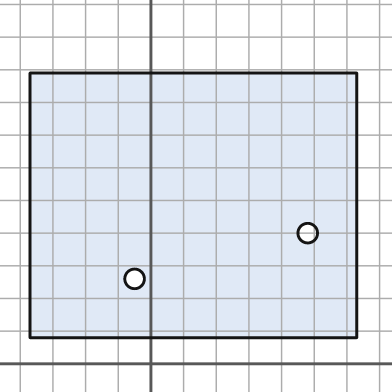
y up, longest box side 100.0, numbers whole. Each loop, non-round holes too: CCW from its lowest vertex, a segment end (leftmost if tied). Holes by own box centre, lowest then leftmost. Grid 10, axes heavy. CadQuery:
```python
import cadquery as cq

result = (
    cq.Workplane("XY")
    .moveTo(-37.0, 8.0)
    .lineTo(63.0, 8.0)
    .lineTo(63.0, 89.0)
    .lineTo(-37.0, 89.0)
    .close()
    .moveTo(-5.0, 26.0)
    .circle(3.0)
    .moveTo(48.0, 40.0)
    .circle(3.0)
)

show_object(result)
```